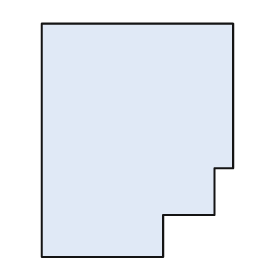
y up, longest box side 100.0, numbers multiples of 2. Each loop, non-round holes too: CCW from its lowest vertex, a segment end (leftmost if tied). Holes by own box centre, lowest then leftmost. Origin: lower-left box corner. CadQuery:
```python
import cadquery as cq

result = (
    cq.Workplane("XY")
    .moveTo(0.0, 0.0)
    .lineTo(52.0, 0.0)
    .lineTo(52.0, 18.0)
    .lineTo(74.0, 18.0)
    .lineTo(74.0, 38.0)
    .lineTo(82.0, 38.0)
    .lineTo(82.0, 100.0)
    .lineTo(0.0, 100.0)
    .close()
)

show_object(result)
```